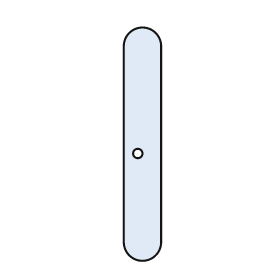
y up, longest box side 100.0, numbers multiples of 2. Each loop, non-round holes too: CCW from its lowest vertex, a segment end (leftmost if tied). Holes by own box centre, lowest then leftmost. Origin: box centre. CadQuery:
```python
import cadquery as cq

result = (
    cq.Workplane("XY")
    .moveTo(-8.0, -42.0)
    .threePointArc((0.0, -50.0), (8.0, -42.0))
    .lineTo(8.0, 42.0)
    .threePointArc((0.0, 50.0), (-8.0, 42.0))
    .close()
    .moveTo(-2.0, -4.0)
    .circle(2.0)
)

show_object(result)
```